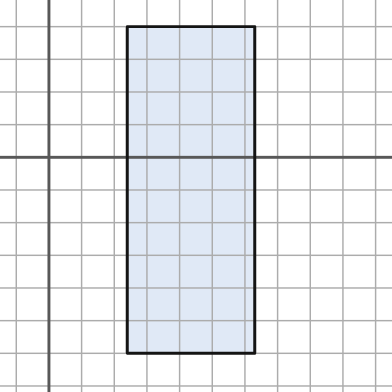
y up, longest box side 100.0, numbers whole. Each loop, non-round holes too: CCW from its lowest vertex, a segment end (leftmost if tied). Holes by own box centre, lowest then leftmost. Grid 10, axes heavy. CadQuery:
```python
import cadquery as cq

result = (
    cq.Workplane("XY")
    .moveTo(24.0, -60.0)
    .lineTo(63.0, -60.0)
    .lineTo(63.0, 40.0)
    .lineTo(24.0, 40.0)
    .close()
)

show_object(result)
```